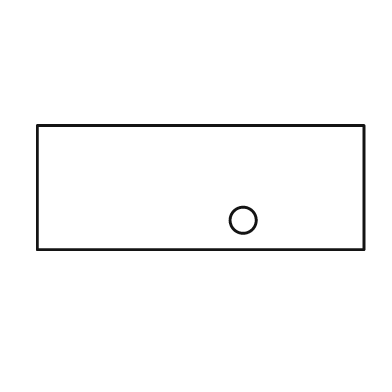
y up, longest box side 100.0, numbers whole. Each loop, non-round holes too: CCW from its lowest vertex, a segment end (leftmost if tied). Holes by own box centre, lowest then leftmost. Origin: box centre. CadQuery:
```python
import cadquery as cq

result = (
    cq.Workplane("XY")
    .moveTo(-50.0, -19.0)
    .lineTo(50.0, -19.0)
    .lineTo(50.0, 19.0)
    .lineTo(-50.0, 19.0)
    .close()
    .moveTo(13.0, -10.0)
    .circle(4.0)
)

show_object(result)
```